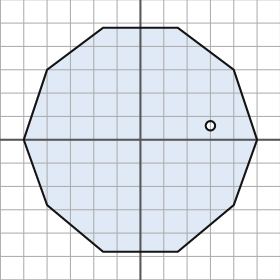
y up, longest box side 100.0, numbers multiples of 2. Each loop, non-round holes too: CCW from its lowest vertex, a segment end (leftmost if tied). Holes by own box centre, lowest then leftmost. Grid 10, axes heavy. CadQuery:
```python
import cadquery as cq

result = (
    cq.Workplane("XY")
    .moveTo(-16.0, -48.0)
    .lineTo(16.0, -48.0)
    .lineTo(40.0, -28.0)
    .lineTo(50.0, 0.0)
    .lineTo(40.0, 30.0)
    .lineTo(16.0, 48.0)
    .lineTo(-16.0, 48.0)
    .lineTo(-40.0, 30.0)
    .lineTo(-50.0, 0.0)
    .lineTo(-40.0, -28.0)
    .close()
    .moveTo(30.0, 6.0)
    .circle(2.0)
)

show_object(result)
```